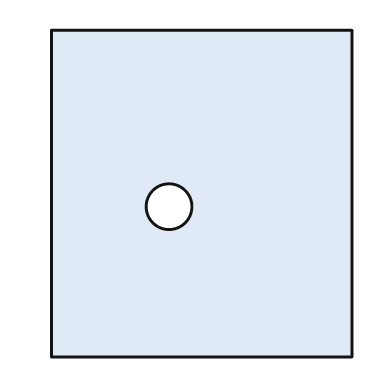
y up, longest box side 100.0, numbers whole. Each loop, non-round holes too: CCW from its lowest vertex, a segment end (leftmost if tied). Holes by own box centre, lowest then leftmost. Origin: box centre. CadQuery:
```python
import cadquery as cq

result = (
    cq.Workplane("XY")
    .moveTo(-46.0, -50.0)
    .lineTo(46.0, -50.0)
    .lineTo(46.0, 50.0)
    .lineTo(-46.0, 50.0)
    .close()
    .moveTo(-10.0, -4.0)
    .circle(7.0)
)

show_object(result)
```